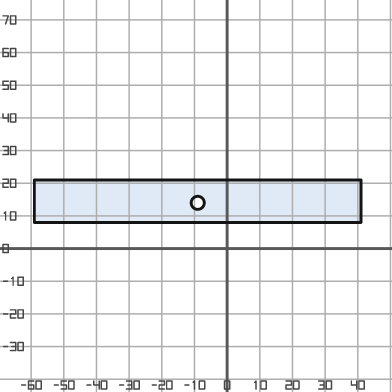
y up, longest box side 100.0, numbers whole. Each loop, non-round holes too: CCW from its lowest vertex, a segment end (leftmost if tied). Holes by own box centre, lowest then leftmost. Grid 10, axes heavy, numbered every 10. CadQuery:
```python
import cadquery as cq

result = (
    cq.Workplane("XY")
    .moveTo(-59.0, 8.0)
    .lineTo(41.0, 8.0)
    .lineTo(41.0, 21.0)
    .lineTo(-59.0, 21.0)
    .close()
    .moveTo(-9.0, 14.0)
    .circle(2.0)
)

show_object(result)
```